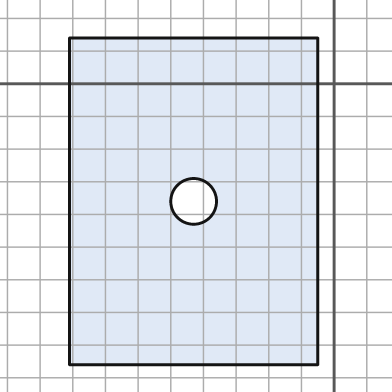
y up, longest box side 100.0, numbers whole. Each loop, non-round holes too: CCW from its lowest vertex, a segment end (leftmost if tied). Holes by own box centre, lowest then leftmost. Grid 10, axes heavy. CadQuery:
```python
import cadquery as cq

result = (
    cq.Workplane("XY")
    .moveTo(-81.0, -86.0)
    .lineTo(-5.0, -86.0)
    .lineTo(-5.0, 14.0)
    .lineTo(-81.0, 14.0)
    .close()
    .moveTo(-43.0, -36.0)
    .circle(7.0)
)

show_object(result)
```